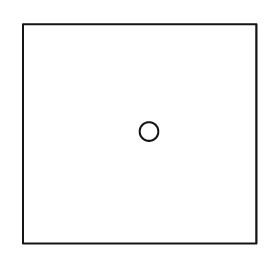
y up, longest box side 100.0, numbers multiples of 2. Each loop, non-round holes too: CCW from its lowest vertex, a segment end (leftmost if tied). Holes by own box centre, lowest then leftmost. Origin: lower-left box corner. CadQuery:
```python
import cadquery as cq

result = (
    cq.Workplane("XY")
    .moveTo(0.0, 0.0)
    .lineTo(100.0, 0.0)
    .lineTo(100.0, 94.0)
    .lineTo(0.0, 94.0)
    .close()
    .moveTo(54.0, 48.0)
    .circle(4.0)
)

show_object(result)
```